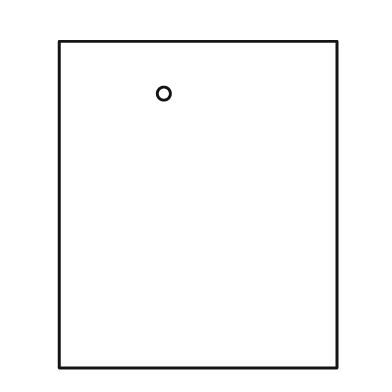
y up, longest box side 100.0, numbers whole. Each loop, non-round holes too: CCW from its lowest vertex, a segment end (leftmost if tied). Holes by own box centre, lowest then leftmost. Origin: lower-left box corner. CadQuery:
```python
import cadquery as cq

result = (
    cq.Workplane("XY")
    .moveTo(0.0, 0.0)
    .lineTo(85.0, 0.0)
    .lineTo(85.0, 100.0)
    .lineTo(0.0, 100.0)
    .close()
    .moveTo(32.0, 84.0)
    .circle(2.0)
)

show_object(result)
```